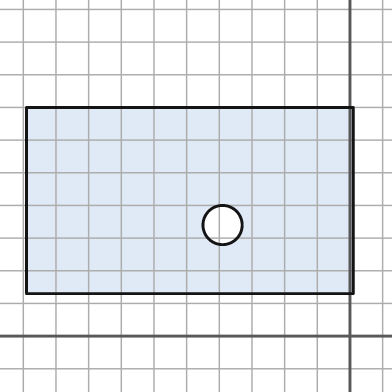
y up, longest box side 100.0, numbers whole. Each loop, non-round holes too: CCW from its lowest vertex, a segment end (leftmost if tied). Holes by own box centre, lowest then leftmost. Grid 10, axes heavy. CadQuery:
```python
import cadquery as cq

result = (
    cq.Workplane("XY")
    .moveTo(-99.0, 13.0)
    .lineTo(1.0, 13.0)
    .lineTo(1.0, 70.0)
    .lineTo(-99.0, 70.0)
    .close()
    .moveTo(-39.0, 34.0)
    .circle(6.0)
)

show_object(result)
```